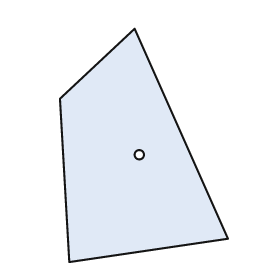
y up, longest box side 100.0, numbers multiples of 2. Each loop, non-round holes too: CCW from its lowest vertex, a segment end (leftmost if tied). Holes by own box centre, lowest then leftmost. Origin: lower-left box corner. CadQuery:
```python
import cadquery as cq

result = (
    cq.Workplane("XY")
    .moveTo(4.0, 0.0)
    .lineTo(72.0, 10.0)
    .lineTo(32.0, 100.0)
    .lineTo(0.0, 70.0)
    .close()
    .moveTo(34.0, 46.0)
    .circle(2.0)
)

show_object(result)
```